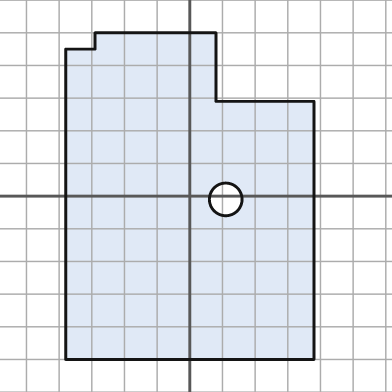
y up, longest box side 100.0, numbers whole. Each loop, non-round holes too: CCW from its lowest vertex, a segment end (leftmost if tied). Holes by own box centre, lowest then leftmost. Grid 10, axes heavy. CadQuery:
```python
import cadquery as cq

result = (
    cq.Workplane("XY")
    .moveTo(-38.0, -50.0)
    .lineTo(38.0, -50.0)
    .lineTo(38.0, 29.0)
    .lineTo(8.0, 29.0)
    .lineTo(8.0, 50.0)
    .lineTo(-29.0, 50.0)
    .lineTo(-29.0, 45.0)
    .lineTo(-38.0, 45.0)
    .close()
    .moveTo(11.0, -1.0)
    .circle(5.0)
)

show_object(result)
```